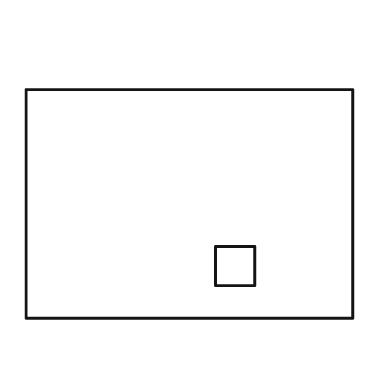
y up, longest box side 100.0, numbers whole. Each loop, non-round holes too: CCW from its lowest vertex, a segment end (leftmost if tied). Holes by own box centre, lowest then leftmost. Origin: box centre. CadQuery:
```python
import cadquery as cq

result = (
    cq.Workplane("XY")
    .moveTo(-50.0, -35.0)
    .lineTo(50.0, -35.0)
    .lineTo(50.0, 35.0)
    .lineTo(-50.0, 35.0)
    .close()
    .moveTo(8.0, -25.0)
    .lineTo(20.0, -25.0)
    .lineTo(20.0, -13.0)
    .lineTo(8.0, -13.0)
    .close()
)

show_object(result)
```